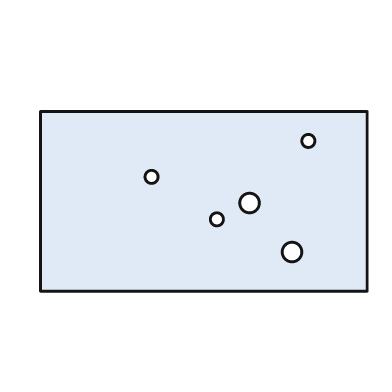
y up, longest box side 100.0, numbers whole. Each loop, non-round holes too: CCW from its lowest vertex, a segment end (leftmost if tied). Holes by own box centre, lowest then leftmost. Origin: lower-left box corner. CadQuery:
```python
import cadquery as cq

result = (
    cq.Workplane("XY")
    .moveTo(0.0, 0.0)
    .lineTo(100.0, 0.0)
    .lineTo(100.0, 55.0)
    .lineTo(0.0, 55.0)
    .close()
    .moveTo(77.0, 12.0)
    .circle(3.0)
    .moveTo(54.0, 22.0)
    .circle(2.0)
    .moveTo(64.0, 27.0)
    .circle(3.0)
    .moveTo(34.0, 35.0)
    .circle(2.0)
    .moveTo(82.0, 46.0)
    .circle(2.0)
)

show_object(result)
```